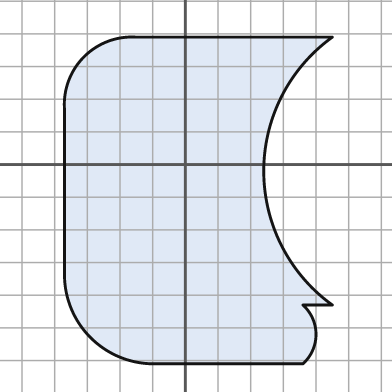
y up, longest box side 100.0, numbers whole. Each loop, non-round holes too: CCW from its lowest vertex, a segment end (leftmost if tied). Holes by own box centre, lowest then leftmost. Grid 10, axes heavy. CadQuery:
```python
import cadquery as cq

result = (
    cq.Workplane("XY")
    .moveTo(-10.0, -61.0)
    .lineTo(36.0, -61.0)
    .threePointArc((40.0, -52.0), (36.0, -43.0))
    .lineTo(45.0, -43.0)
    .threePointArc((24.0, -2.0), (45.0, 39.0))
    .lineTo(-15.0, 39.0)
    .threePointArc((-31.0, 33.0), (-37.0, 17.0))
    .lineTo(-37.0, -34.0)
    .threePointArc((-29.0, -53.0), (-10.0, -61.0))
    .close()
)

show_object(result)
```